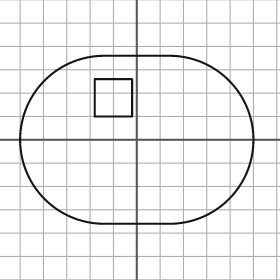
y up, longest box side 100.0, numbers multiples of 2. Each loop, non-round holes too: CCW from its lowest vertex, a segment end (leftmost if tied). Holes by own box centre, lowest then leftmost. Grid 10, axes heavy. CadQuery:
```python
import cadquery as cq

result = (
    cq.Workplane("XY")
    .moveTo(-14.0, -36.0)
    .lineTo(14.0, -36.0)
    .threePointArc((50.0, 0.0), (14.0, 36.0))
    .lineTo(-14.0, 36.0)
    .threePointArc((-50.0, 0.0), (-14.0, -36.0))
    .close()
    .moveTo(-18.0, 10.0)
    .lineTo(-2.0, 10.0)
    .lineTo(-2.0, 26.0)
    .lineTo(-18.0, 26.0)
    .close()
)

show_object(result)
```